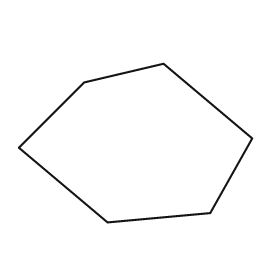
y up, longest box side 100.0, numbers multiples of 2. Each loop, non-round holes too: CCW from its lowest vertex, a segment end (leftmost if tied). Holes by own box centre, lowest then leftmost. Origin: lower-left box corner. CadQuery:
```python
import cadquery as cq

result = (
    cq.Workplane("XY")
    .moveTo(38.0, 0.0)
    .lineTo(82.0, 4.0)
    .lineTo(100.0, 36.0)
    .lineTo(62.0, 68.0)
    .lineTo(28.0, 60.0)
    .lineTo(0.0, 32.0)
    .close()
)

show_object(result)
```